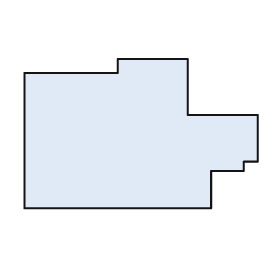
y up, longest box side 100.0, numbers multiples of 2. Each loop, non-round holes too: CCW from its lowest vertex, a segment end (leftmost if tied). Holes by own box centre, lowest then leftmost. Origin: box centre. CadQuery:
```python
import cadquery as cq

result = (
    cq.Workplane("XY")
    .moveTo(-50.0, -32.0)
    .lineTo(30.0, -32.0)
    .lineTo(30.0, -16.0)
    .lineTo(44.0, -16.0)
    .lineTo(44.0, -12.0)
    .lineTo(50.0, -12.0)
    .lineTo(50.0, 8.0)
    .lineTo(20.0, 8.0)
    .lineTo(20.0, 32.0)
    .lineTo(-10.0, 32.0)
    .lineTo(-10.0, 26.0)
    .lineTo(-50.0, 26.0)
    .close()
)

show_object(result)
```